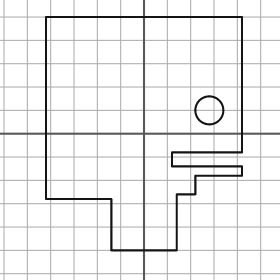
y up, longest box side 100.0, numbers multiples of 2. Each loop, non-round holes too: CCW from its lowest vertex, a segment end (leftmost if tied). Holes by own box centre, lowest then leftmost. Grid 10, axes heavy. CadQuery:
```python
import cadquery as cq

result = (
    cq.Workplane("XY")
    .moveTo(-14.0, -50.0)
    .lineTo(14.0, -50.0)
    .lineTo(14.0, -26.0)
    .lineTo(22.0, -26.0)
    .lineTo(22.0, -18.0)
    .lineTo(42.0, -18.0)
    .lineTo(42.0, -14.0)
    .lineTo(12.0, -14.0)
    .lineTo(12.0, -8.0)
    .lineTo(42.0, -8.0)
    .lineTo(42.0, 50.0)
    .lineTo(-42.0, 50.0)
    .lineTo(-42.0, -28.0)
    .lineTo(-14.0, -28.0)
    .close()
    .moveTo(28.0, 10.0)
    .circle(6.0)
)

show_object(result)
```